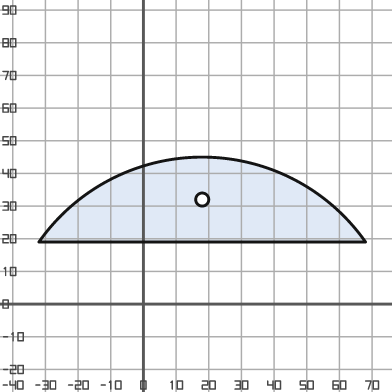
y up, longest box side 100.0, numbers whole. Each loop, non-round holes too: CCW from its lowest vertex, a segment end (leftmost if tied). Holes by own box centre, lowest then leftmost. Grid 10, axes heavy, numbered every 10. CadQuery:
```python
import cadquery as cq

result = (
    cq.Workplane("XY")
    .moveTo(-32.0, 19.0)
    .lineTo(68.0, 19.0)
    .threePointArc((18.0, 45.0), (-32.0, 19.0))
    .close()
    .moveTo(18.0, 32.0)
    .circle(2.0)
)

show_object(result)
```